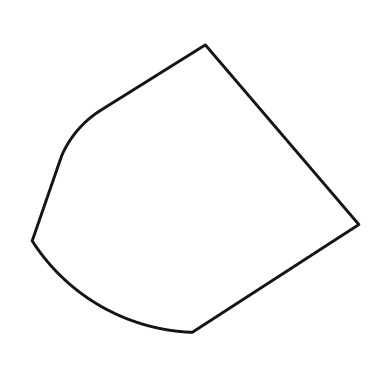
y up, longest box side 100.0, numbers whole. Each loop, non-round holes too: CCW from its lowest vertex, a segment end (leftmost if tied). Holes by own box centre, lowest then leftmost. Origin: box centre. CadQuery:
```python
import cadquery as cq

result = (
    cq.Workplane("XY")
    .moveTo(-1.0, -44.0)
    .lineTo(50.0, -11.0)
    .lineTo(3.0, 44.0)
    .lineTo(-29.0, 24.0)
    .threePointArc((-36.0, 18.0), (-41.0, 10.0))
    .lineTo(-50.0, -16.0)
    .threePointArc((-29.0, -36.0), (-1.0, -44.0))
    .close()
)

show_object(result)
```